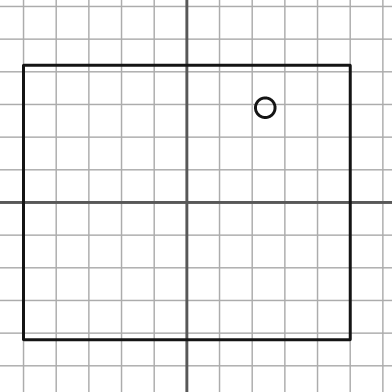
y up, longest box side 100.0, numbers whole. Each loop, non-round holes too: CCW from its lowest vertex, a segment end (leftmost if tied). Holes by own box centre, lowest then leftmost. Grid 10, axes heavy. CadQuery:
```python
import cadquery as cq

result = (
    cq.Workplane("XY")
    .moveTo(-50.0, -42.0)
    .lineTo(50.0, -42.0)
    .lineTo(50.0, 42.0)
    .lineTo(-50.0, 42.0)
    .close()
    .moveTo(24.0, 29.0)
    .circle(3.0)
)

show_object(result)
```